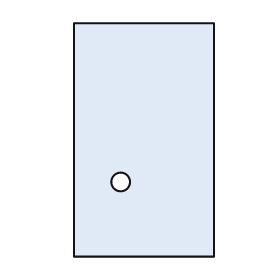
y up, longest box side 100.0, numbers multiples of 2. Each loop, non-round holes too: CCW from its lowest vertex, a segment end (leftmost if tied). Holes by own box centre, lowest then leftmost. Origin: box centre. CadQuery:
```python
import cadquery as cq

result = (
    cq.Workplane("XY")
    .moveTo(-30.0, -50.0)
    .lineTo(30.0, -50.0)
    .lineTo(30.0, 50.0)
    .lineTo(-30.0, 50.0)
    .close()
    .moveTo(-10.0, -18.0)
    .circle(4.0)
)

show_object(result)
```